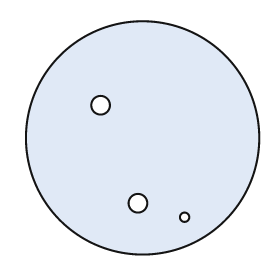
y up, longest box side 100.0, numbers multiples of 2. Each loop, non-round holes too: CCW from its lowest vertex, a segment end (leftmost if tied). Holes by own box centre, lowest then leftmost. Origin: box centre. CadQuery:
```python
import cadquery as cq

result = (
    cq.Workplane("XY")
    .moveTo(0.0, 0.0)
    .circle(50.0)
    .moveTo(18.0, -34.0)
    .circle(2.0)
    .moveTo(-2.0, -28.0)
    .circle(4.0)
    .moveTo(-18.0, 14.0)
    .circle(4.0)
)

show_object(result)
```